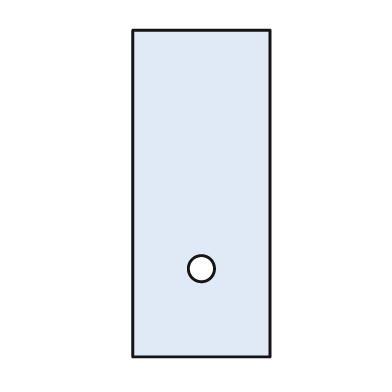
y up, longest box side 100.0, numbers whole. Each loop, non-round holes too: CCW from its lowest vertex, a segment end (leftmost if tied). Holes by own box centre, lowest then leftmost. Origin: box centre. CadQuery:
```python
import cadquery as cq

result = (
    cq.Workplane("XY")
    .moveTo(-21.0, -50.0)
    .lineTo(21.0, -50.0)
    .lineTo(21.0, 50.0)
    .lineTo(-21.0, 50.0)
    .close()
    .moveTo(0.0, -23.0)
    .circle(4.0)
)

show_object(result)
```